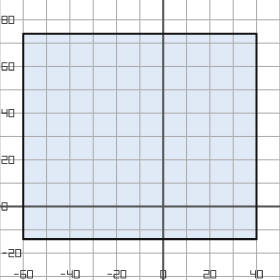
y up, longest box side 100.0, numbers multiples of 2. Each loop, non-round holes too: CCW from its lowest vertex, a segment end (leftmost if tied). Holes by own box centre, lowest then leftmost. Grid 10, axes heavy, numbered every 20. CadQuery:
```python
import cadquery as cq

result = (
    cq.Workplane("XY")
    .moveTo(-60.0, -14.0)
    .lineTo(40.0, -14.0)
    .lineTo(40.0, 74.0)
    .lineTo(-60.0, 74.0)
    .close()
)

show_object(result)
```